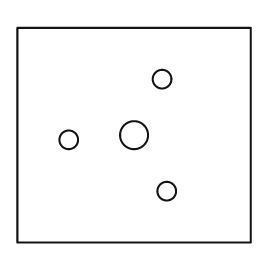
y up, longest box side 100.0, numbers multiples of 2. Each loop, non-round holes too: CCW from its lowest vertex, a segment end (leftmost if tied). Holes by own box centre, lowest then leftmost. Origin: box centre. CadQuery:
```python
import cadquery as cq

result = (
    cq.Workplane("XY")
    .moveTo(-50.0, -46.0)
    .lineTo(50.0, -46.0)
    .lineTo(50.0, 46.0)
    .lineTo(-50.0, 46.0)
    .close()
    .moveTo(14.0, -24.0)
    .circle(4.0)
    .moveTo(-28.0, -2.0)
    .circle(4.0)
    .moveTo(0.0, 0.0)
    .circle(6.0)
    .moveTo(12.0, 24.0)
    .circle(4.0)
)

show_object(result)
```